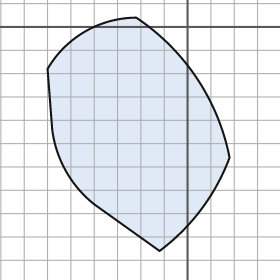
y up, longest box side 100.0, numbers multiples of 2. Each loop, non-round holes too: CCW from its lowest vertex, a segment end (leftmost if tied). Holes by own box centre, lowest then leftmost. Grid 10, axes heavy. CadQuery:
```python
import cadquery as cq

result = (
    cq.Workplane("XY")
    .moveTo(-12.0, -96.0)
    .threePointArc((6.0, -78.0), (18.0, -56.0))
    .threePointArc((4.0, -22.0), (-22.0, 4.0))
    .threePointArc((-44.0, -2.0), (-60.0, -18.0))
    .lineTo(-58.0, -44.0)
    .threePointArc((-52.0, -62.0), (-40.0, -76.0))
    .close()
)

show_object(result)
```